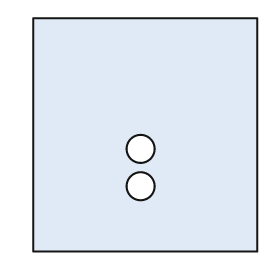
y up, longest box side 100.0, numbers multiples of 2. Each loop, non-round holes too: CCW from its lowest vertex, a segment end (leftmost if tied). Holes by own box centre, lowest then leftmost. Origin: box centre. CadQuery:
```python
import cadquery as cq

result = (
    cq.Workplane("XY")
    .moveTo(-48.0, -50.0)
    .lineTo(48.0, -50.0)
    .lineTo(48.0, 50.0)
    .lineTo(-48.0, 50.0)
    .close()
    .moveTo(-2.0, -22.0)
    .circle(6.0)
    .moveTo(-2.0, -6.0)
    .circle(6.0)
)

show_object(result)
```